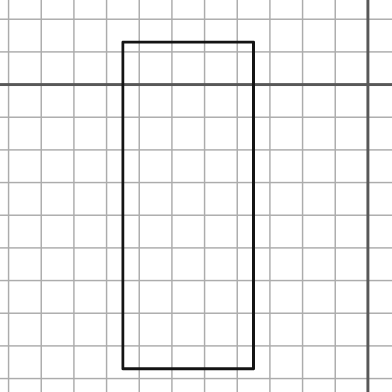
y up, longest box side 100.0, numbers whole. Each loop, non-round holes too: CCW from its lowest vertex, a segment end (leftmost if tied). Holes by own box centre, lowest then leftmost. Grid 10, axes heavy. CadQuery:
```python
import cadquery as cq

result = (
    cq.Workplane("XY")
    .moveTo(-75.0, -87.0)
    .lineTo(-35.0, -87.0)
    .lineTo(-35.0, 13.0)
    .lineTo(-75.0, 13.0)
    .close()
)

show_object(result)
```